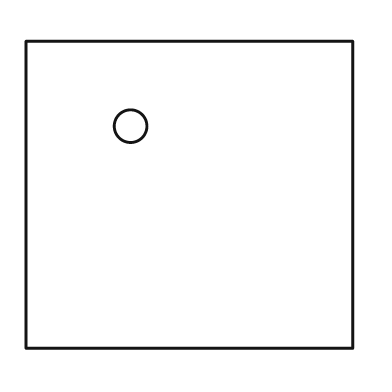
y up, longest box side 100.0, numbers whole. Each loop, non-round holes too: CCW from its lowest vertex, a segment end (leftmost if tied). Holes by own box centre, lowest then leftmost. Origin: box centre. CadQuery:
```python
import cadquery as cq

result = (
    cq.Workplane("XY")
    .moveTo(-50.0, -47.0)
    .lineTo(50.0, -47.0)
    .lineTo(50.0, 47.0)
    .lineTo(-50.0, 47.0)
    .close()
    .moveTo(-18.0, 21.0)
    .circle(5.0)
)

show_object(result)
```